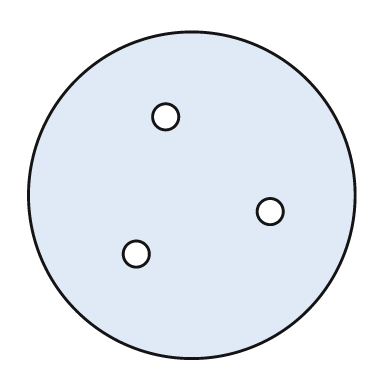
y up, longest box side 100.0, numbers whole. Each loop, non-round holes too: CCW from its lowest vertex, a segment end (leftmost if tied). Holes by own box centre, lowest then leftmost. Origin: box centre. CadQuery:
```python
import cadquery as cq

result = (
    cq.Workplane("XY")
    .moveTo(0.0, 0.0)
    .circle(50.0)
    .moveTo(-17.0, -18.0)
    .circle(4.0)
    .moveTo(24.0, -5.0)
    .circle(4.0)
    .moveTo(-8.0, 24.0)
    .circle(4.0)
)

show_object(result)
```